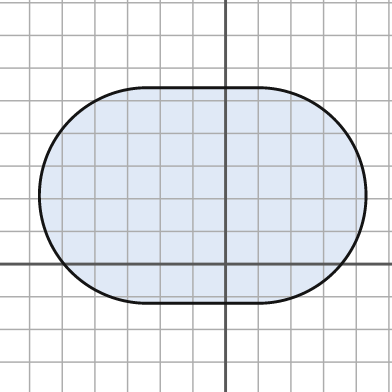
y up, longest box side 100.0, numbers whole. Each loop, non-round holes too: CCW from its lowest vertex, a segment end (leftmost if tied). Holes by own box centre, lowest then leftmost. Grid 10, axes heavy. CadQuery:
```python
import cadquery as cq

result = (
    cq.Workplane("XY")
    .moveTo(-24.0, -12.0)
    .lineTo(10.0, -12.0)
    .threePointArc((43.0, 21.0), (10.0, 54.0))
    .lineTo(-24.0, 54.0)
    .threePointArc((-57.0, 21.0), (-24.0, -12.0))
    .close()
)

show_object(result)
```